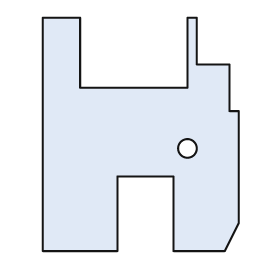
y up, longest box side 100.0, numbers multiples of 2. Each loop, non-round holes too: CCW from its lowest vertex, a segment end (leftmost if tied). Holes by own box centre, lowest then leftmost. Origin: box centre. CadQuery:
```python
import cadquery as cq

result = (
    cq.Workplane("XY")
    .moveTo(-42.0, -50.0)
    .lineTo(-10.0, -50.0)
    .lineTo(-10.0, -18.0)
    .lineTo(14.0, -18.0)
    .lineTo(14.0, -50.0)
    .lineTo(36.0, -50.0)
    .lineTo(42.0, -38.0)
    .lineTo(42.0, 10.0)
    .lineTo(38.0, 10.0)
    .lineTo(38.0, 30.0)
    .lineTo(24.0, 30.0)
    .lineTo(24.0, 50.0)
    .lineTo(20.0, 50.0)
    .lineTo(20.0, 20.0)
    .lineTo(-26.0, 20.0)
    .lineTo(-26.0, 50.0)
    .lineTo(-42.0, 50.0)
    .close()
    .moveTo(20.0, -6.0)
    .circle(4.0)
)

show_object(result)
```